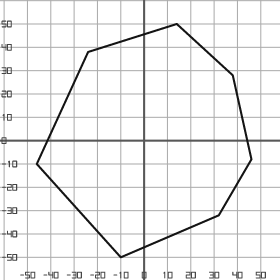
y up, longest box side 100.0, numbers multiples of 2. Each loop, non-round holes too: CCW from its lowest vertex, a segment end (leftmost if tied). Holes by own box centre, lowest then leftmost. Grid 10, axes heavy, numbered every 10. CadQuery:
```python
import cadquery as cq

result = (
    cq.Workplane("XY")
    .moveTo(-10.0, -50.0)
    .lineTo(32.0, -32.0)
    .lineTo(46.0, -8.0)
    .lineTo(38.0, 28.0)
    .lineTo(14.0, 50.0)
    .lineTo(-24.0, 38.0)
    .lineTo(-46.0, -10.0)
    .close()
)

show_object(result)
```